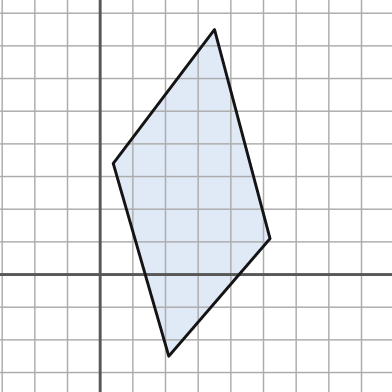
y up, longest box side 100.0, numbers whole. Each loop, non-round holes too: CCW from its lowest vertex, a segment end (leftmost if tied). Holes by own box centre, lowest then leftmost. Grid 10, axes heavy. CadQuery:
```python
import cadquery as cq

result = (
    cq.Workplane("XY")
    .moveTo(21.0, -25.0)
    .lineTo(52.0, 11.0)
    .lineTo(35.0, 75.0)
    .lineTo(4.0, 34.0)
    .close()
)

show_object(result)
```